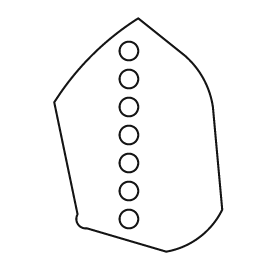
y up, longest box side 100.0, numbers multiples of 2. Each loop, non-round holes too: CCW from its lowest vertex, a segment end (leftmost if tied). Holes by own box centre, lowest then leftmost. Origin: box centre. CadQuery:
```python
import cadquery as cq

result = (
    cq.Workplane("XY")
    .moveTo(12.0, -50.0)
    .threePointArc((26.0, -44.0), (36.0, -32.0))
    .lineTo(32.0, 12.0)
    .threePointArc((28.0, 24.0), (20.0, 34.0))
    .lineTo(0.0, 50.0)
    .threePointArc((-20.0, 34.0), (-36.0, 14.0))
    .lineTo(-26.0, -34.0)
    .threePointArc((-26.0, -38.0), (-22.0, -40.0))
    .close()
    .moveTo(-4.0, -36.0)
    .circle(4.0)
    .moveTo(-4.0, -24.0)
    .circle(4.0)
    .moveTo(-4.0, -12.0)
    .circle(4.0)
    .moveTo(-4.0, 0.0)
    .circle(4.0)
    .moveTo(-4.0, 12.0)
    .circle(4.0)
    .moveTo(-4.0, 24.0)
    .circle(4.0)
    .moveTo(-4.0, 36.0)
    .circle(4.0)
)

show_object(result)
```